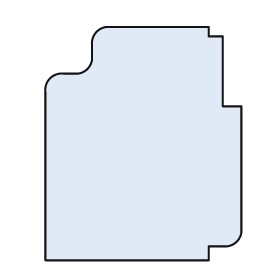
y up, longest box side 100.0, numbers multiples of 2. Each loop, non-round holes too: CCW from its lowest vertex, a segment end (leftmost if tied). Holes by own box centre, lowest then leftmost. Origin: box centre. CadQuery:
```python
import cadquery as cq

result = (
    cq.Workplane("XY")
    .moveTo(-42.0, -50.0)
    .lineTo(28.0, -50.0)
    .lineTo(28.0, -44.0)
    .lineTo(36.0, -44.0)
    .threePointArc((40.0, -42.0), (42.0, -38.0))
    .lineTo(42.0, 16.0)
    .lineTo(34.0, 16.0)
    .lineTo(34.0, 46.0)
    .lineTo(28.0, 46.0)
    .lineTo(28.0, 50.0)
    .lineTo(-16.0, 50.0)
    .threePointArc((-20.0, 48.0), (-22.0, 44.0))
    .lineTo(-22.0, 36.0)
    .threePointArc((-24.0, 32.0), (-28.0, 30.0))
    .lineTo(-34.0, 30.0)
    .threePointArc((-40.0, 28.0), (-42.0, 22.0))
    .close()
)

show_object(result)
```